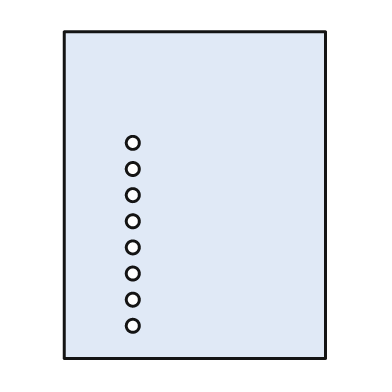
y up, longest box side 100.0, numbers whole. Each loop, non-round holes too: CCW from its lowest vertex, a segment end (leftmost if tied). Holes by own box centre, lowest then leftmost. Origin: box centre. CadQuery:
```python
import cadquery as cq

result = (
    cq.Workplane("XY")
    .moveTo(-40.0, -50.0)
    .lineTo(40.0, -50.0)
    .lineTo(40.0, 50.0)
    .lineTo(-40.0, 50.0)
    .close()
    .moveTo(-19.0, -40.0)
    .circle(2.0)
    .moveTo(-19.0, -32.0)
    .circle(2.0)
    .moveTo(-19.0, -24.0)
    .circle(2.0)
    .moveTo(-19.0, -16.0)
    .circle(2.0)
    .moveTo(-19.0, -8.0)
    .circle(2.0)
    .moveTo(-19.0, 0.0)
    .circle(2.0)
    .moveTo(-19.0, 8.0)
    .circle(2.0)
    .moveTo(-19.0, 16.0)
    .circle(2.0)
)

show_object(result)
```